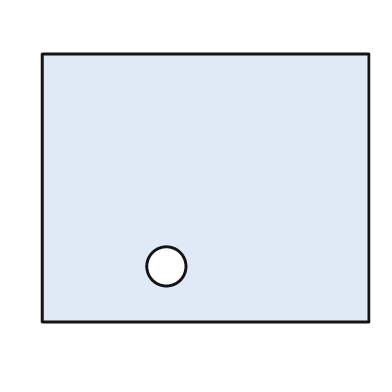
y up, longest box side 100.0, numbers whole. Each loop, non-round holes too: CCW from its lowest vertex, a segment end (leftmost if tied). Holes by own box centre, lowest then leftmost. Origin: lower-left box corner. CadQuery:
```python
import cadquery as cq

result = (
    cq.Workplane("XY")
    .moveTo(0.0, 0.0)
    .lineTo(100.0, 0.0)
    .lineTo(100.0, 82.0)
    .lineTo(0.0, 82.0)
    .close()
    .moveTo(38.0, 17.0)
    .circle(6.0)
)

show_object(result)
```